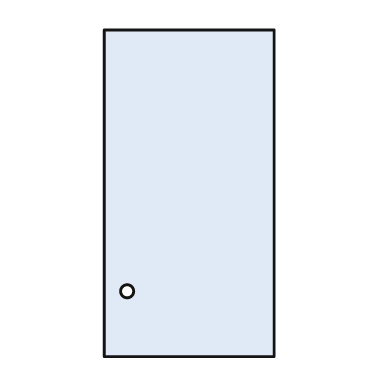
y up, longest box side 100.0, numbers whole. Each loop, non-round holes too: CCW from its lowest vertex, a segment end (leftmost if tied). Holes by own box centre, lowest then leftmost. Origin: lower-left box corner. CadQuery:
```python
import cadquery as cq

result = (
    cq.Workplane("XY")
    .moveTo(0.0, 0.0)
    .lineTo(52.0, 0.0)
    .lineTo(52.0, 100.0)
    .lineTo(0.0, 100.0)
    .close()
    .moveTo(7.0, 20.0)
    .circle(2.0)
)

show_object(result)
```